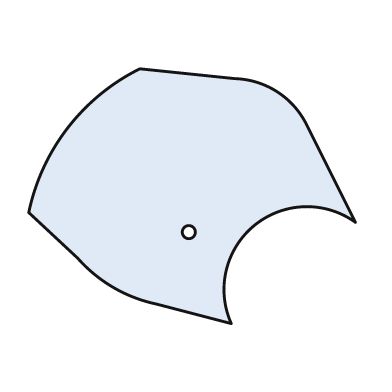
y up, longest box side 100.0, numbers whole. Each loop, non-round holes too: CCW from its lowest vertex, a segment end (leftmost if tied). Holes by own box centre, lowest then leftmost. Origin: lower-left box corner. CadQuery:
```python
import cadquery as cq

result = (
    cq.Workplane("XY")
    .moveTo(62.0, 0.0)
    .threePointArc((69.0, 30.0), (100.0, 31.0))
    .lineTo(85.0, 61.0)
    .threePointArc((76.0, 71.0), (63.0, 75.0))
    .lineTo(34.0, 78.0)
    .threePointArc((12.0, 60.0), (0.0, 34.0))
    .lineTo(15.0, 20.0)
    .threePointArc((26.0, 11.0), (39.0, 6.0))
    .close()
    .moveTo(49.0, 28.0)
    .circle(2.0)
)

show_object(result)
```